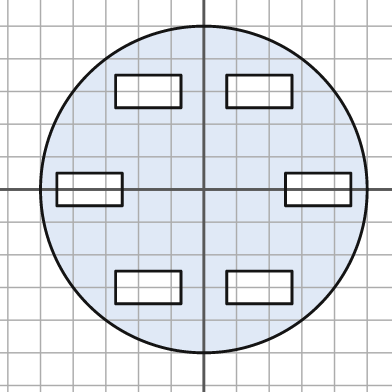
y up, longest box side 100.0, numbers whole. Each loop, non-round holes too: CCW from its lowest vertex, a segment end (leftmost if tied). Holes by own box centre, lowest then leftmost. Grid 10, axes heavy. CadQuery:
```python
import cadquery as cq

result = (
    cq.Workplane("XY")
    .moveTo(0.0, 0.0)
    .circle(50.0)
    .moveTo(-27.0, -35.0)
    .lineTo(-7.0, -35.0)
    .lineTo(-7.0, -25.0)
    .lineTo(-27.0, -25.0)
    .close()
    .moveTo(7.0, -35.0)
    .lineTo(27.0, -35.0)
    .lineTo(27.0, -25.0)
    .lineTo(7.0, -25.0)
    .close()
    .moveTo(-45.0, -5.0)
    .lineTo(-25.0, -5.0)
    .lineTo(-25.0, 5.0)
    .lineTo(-45.0, 5.0)
    .close()
    .moveTo(25.0, -5.0)
    .lineTo(45.0, -5.0)
    .lineTo(45.0, 5.0)
    .lineTo(25.0, 5.0)
    .close()
    .moveTo(-27.0, 25.0)
    .lineTo(-7.0, 25.0)
    .lineTo(-7.0, 35.0)
    .lineTo(-27.0, 35.0)
    .close()
    .moveTo(7.0, 25.0)
    .lineTo(27.0, 25.0)
    .lineTo(27.0, 35.0)
    .lineTo(7.0, 35.0)
    .close()
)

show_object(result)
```